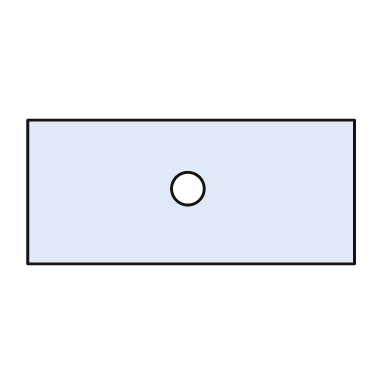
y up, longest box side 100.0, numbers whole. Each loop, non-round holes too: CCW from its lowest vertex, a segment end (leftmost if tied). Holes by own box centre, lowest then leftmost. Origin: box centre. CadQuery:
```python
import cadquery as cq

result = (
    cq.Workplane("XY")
    .moveTo(-50.0, -22.0)
    .lineTo(50.0, -22.0)
    .lineTo(50.0, 22.0)
    .lineTo(-50.0, 22.0)
    .close()
    .moveTo(-1.0, 1.0)
    .circle(5.0)
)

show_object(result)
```